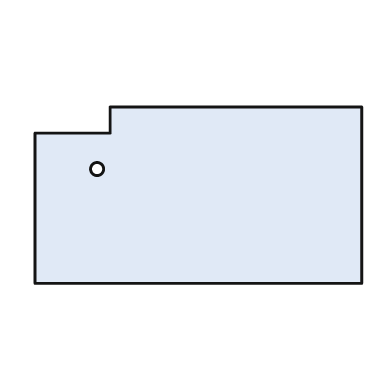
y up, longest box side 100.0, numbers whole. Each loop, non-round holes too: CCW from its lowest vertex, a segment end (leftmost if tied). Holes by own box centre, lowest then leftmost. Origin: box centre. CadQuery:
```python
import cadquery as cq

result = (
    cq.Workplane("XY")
    .moveTo(-50.0, -27.0)
    .lineTo(50.0, -27.0)
    .lineTo(50.0, 27.0)
    .lineTo(-27.0, 27.0)
    .lineTo(-27.0, 19.0)
    .lineTo(-50.0, 19.0)
    .close()
    .moveTo(-31.0, 8.0)
    .circle(2.0)
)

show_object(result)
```